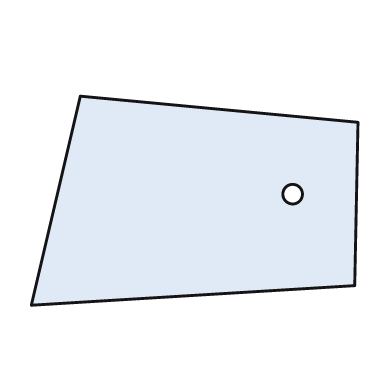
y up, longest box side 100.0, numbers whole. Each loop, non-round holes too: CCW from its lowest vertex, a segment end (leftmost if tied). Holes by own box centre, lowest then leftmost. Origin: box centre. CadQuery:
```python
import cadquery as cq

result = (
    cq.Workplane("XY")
    .moveTo(-50.0, -32.0)
    .lineTo(49.0, -26.0)
    .lineTo(50.0, 24.0)
    .lineTo(-35.0, 32.0)
    .close()
    .moveTo(30.0, 2.0)
    .circle(3.0)
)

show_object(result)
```